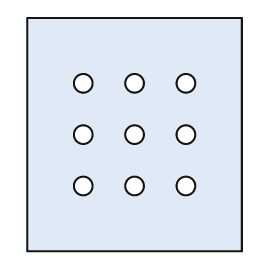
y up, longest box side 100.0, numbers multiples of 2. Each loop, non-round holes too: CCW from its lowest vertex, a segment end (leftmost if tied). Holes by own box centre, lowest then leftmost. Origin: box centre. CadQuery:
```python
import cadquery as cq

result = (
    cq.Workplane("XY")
    .moveTo(-46.0, -50.0)
    .lineTo(46.0, -50.0)
    .lineTo(46.0, 50.0)
    .lineTo(-46.0, 50.0)
    .close()
    .moveTo(-22.0, -22.0)
    .circle(4.0)
    .moveTo(0.0, -22.0)
    .circle(4.0)
    .moveTo(22.0, -22.0)
    .circle(4.0)
    .moveTo(-22.0, 0.0)
    .circle(4.0)
    .moveTo(0.0, 0.0)
    .circle(4.0)
    .moveTo(22.0, 0.0)
    .circle(4.0)
    .moveTo(-22.0, 22.0)
    .circle(4.0)
    .moveTo(0.0, 22.0)
    .circle(4.0)
    .moveTo(22.0, 22.0)
    .circle(4.0)
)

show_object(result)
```